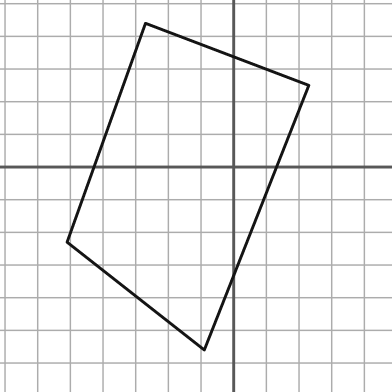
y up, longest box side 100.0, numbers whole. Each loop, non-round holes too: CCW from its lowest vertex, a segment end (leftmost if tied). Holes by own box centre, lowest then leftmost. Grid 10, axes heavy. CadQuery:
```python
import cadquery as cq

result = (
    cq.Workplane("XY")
    .moveTo(-9.0, -56.0)
    .lineTo(23.0, 25.0)
    .lineTo(-27.0, 44.0)
    .lineTo(-51.0, -23.0)
    .close()
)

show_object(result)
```